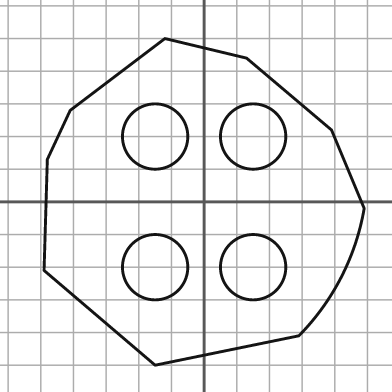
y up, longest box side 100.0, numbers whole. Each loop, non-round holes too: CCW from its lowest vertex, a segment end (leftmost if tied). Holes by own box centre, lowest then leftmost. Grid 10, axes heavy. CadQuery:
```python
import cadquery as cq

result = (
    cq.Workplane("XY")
    .moveTo(-15.0, -50.0)
    .lineTo(29.0, -41.0)
    .threePointArc((42.0, -23.0), (49.0, -2.0))
    .lineTo(39.0, 22.0)
    .lineTo(13.0, 44.0)
    .lineTo(-12.0, 50.0)
    .lineTo(-41.0, 28.0)
    .lineTo(-48.0, 13.0)
    .lineTo(-49.0, -21.0)
    .close()
    .moveTo(-15.0, -20.0)
    .circle(10.0)
    .moveTo(15.0, -20.0)
    .circle(10.0)
    .moveTo(-15.0, 20.0)
    .circle(10.0)
    .moveTo(15.0, 20.0)
    .circle(10.0)
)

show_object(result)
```